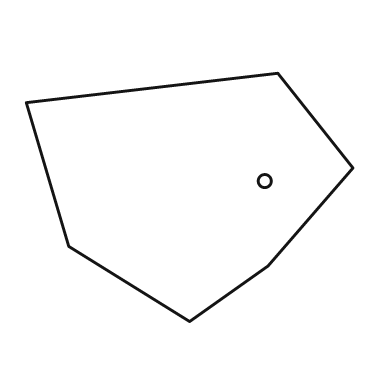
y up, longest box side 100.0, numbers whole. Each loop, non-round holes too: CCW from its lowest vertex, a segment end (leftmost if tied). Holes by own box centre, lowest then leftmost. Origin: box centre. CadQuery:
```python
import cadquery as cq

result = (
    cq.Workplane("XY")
    .moveTo(0.0, -38.0)
    .lineTo(24.0, -21.0)
    .lineTo(50.0, 9.0)
    .lineTo(27.0, 38.0)
    .lineTo(-50.0, 29.0)
    .lineTo(-37.0, -15.0)
    .close()
    .moveTo(23.0, 5.0)
    .circle(2.0)
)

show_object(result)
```